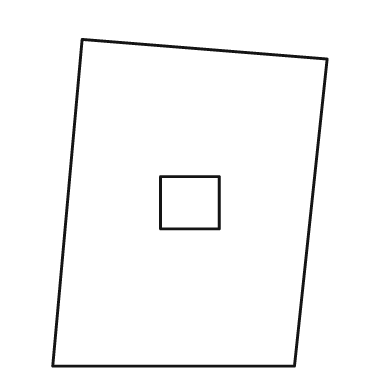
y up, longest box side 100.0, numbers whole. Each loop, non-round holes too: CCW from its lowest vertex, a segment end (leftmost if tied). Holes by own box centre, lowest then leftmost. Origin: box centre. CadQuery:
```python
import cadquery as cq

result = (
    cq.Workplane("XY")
    .moveTo(-42.0, -50.0)
    .lineTo(32.0, -50.0)
    .lineTo(42.0, 44.0)
    .lineTo(-33.0, 50.0)
    .close()
    .moveTo(-9.0, -8.0)
    .lineTo(9.0, -8.0)
    .lineTo(9.0, 8.0)
    .lineTo(-9.0, 8.0)
    .close()
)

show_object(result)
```